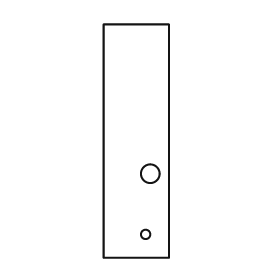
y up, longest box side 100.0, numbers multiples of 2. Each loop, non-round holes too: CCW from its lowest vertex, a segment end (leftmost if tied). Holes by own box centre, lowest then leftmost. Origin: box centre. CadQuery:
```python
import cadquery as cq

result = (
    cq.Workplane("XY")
    .moveTo(-14.0, -50.0)
    .lineTo(14.0, -50.0)
    .lineTo(14.0, 50.0)
    .lineTo(-14.0, 50.0)
    .close()
    .moveTo(4.0, -40.0)
    .circle(2.0)
    .moveTo(6.0, -14.0)
    .circle(4.0)
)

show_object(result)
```